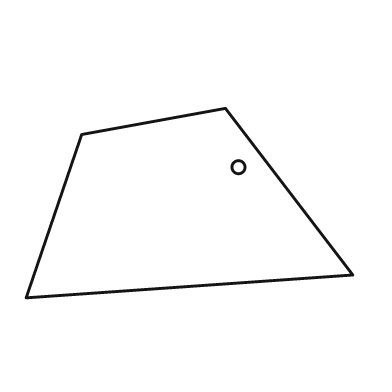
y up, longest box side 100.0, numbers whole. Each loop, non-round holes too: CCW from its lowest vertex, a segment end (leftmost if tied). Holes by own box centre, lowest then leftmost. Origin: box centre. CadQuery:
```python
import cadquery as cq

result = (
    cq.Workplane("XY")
    .moveTo(-50.0, -29.0)
    .lineTo(50.0, -22.0)
    .lineTo(11.0, 29.0)
    .lineTo(-33.0, 21.0)
    .close()
    .moveTo(15.0, 11.0)
    .circle(2.0)
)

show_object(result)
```